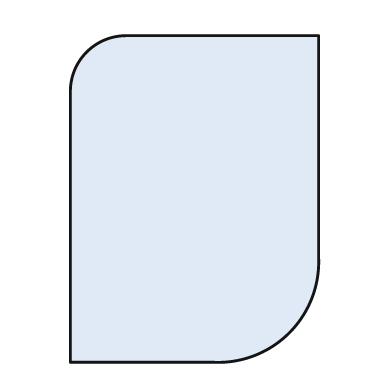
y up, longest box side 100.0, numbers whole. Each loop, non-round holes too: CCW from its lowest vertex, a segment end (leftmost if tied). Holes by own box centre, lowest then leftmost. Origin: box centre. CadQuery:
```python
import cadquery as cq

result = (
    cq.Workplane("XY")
    .moveTo(-38.0, -50.0)
    .lineTo(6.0, -50.0)
    .threePointArc((29.0, -41.0), (38.0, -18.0))
    .lineTo(38.0, 50.0)
    .lineTo(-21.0, 50.0)
    .threePointArc((-33.0, 45.0), (-38.0, 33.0))
    .close()
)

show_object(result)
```